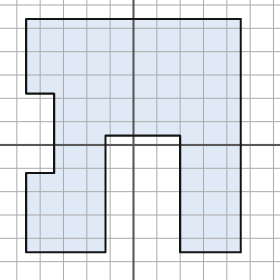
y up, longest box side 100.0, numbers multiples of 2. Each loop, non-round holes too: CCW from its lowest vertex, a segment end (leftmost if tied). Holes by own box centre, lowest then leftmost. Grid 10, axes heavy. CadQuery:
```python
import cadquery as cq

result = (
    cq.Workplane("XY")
    .moveTo(-46.0, -46.0)
    .lineTo(-12.0, -46.0)
    .lineTo(-12.0, 4.0)
    .lineTo(20.0, 4.0)
    .lineTo(20.0, -46.0)
    .lineTo(46.0, -46.0)
    .lineTo(46.0, 54.0)
    .lineTo(-46.0, 54.0)
    .lineTo(-46.0, 22.0)
    .lineTo(-34.0, 22.0)
    .lineTo(-34.0, -12.0)
    .lineTo(-46.0, -12.0)
    .close()
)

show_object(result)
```